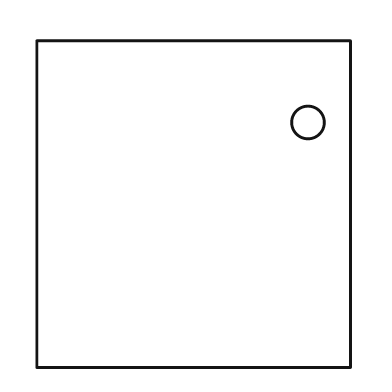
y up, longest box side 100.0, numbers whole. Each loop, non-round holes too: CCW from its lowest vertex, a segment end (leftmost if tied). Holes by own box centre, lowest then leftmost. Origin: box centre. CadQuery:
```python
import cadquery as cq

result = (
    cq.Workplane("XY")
    .moveTo(-48.0, -50.0)
    .lineTo(48.0, -50.0)
    .lineTo(48.0, 50.0)
    .lineTo(-48.0, 50.0)
    .close()
    .moveTo(35.0, 25.0)
    .circle(5.0)
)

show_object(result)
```